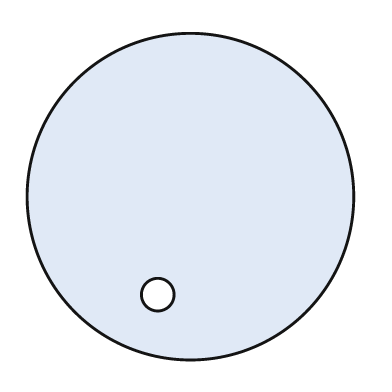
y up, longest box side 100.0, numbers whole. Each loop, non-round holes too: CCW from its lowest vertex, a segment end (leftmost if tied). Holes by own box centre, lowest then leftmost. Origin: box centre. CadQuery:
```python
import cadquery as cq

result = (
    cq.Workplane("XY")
    .moveTo(0.0, 0.0)
    .circle(50.0)
    .moveTo(-10.0, -30.0)
    .circle(5.0)
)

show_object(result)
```